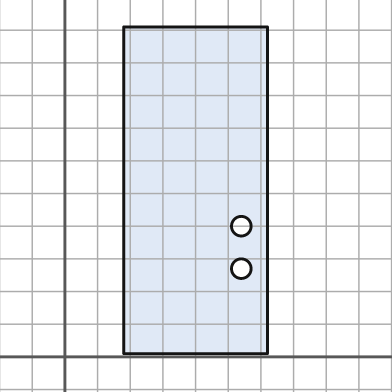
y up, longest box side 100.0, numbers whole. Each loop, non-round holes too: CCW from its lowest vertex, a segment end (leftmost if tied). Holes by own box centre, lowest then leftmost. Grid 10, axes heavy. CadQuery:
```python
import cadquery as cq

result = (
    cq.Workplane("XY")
    .moveTo(18.0, 1.0)
    .lineTo(62.0, 1.0)
    .lineTo(62.0, 101.0)
    .lineTo(18.0, 101.0)
    .close()
    .moveTo(54.0, 27.0)
    .circle(3.0)
    .moveTo(54.0, 40.0)
    .circle(3.0)
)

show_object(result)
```